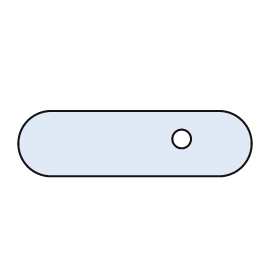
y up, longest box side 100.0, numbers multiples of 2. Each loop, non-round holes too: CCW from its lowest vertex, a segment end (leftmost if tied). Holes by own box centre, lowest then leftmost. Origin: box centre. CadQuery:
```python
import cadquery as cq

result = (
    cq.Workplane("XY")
    .moveTo(-36.0, -14.0)
    .lineTo(36.0, -14.0)
    .threePointArc((50.0, 0.0), (36.0, 14.0))
    .lineTo(-36.0, 14.0)
    .threePointArc((-50.0, 0.0), (-36.0, -14.0))
    .close()
    .moveTo(20.0, 2.0)
    .circle(4.0)
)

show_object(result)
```